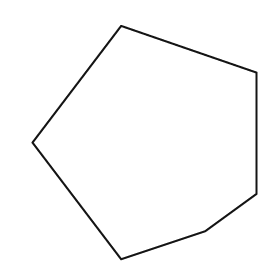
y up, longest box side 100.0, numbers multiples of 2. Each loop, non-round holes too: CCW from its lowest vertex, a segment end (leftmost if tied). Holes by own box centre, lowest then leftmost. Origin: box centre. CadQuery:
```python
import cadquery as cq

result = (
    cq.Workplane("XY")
    .moveTo(-10.0, -50.0)
    .lineTo(26.0, -38.0)
    .lineTo(48.0, -22.0)
    .lineTo(48.0, 30.0)
    .lineTo(-10.0, 50.0)
    .lineTo(-48.0, 0.0)
    .close()
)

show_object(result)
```